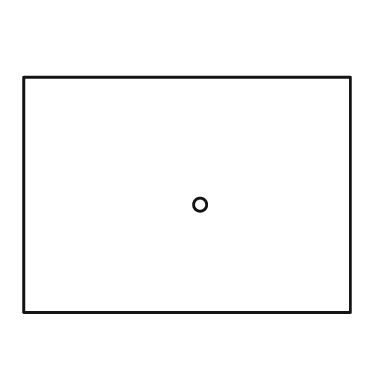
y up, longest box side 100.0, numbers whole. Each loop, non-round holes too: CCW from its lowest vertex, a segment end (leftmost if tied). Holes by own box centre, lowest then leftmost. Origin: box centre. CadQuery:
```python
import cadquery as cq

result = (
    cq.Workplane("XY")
    .moveTo(-50.0, -36.0)
    .lineTo(50.0, -36.0)
    .lineTo(50.0, 36.0)
    .lineTo(-50.0, 36.0)
    .close()
    .moveTo(4.0, -3.0)
    .circle(2.0)
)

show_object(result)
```